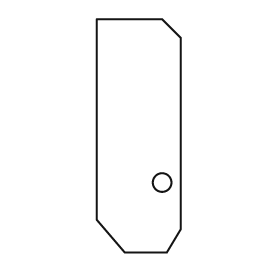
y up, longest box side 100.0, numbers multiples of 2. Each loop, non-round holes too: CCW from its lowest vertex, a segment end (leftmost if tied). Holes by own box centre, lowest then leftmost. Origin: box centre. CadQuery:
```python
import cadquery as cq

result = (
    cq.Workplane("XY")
    .moveTo(-6.0, -50.0)
    .lineTo(12.0, -50.0)
    .lineTo(18.0, -40.0)
    .lineTo(18.0, 42.0)
    .lineTo(10.0, 50.0)
    .lineTo(-18.0, 50.0)
    .lineTo(-18.0, -36.0)
    .close()
    .moveTo(10.0, -20.0)
    .circle(4.0)
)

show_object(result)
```